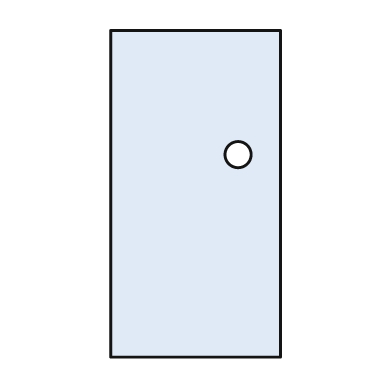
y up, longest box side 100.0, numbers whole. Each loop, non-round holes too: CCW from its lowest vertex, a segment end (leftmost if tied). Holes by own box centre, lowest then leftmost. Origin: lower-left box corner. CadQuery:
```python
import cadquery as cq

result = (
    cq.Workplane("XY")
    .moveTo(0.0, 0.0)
    .lineTo(52.0, 0.0)
    .lineTo(52.0, 100.0)
    .lineTo(0.0, 100.0)
    .close()
    .moveTo(39.0, 62.0)
    .circle(4.0)
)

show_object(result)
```